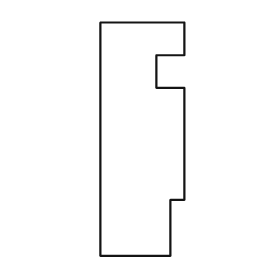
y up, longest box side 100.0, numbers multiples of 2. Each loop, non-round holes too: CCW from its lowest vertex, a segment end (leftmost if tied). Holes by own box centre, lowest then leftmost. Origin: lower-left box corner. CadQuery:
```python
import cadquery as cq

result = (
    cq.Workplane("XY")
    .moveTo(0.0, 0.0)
    .lineTo(30.0, 0.0)
    .lineTo(30.0, 24.0)
    .lineTo(36.0, 24.0)
    .lineTo(36.0, 72.0)
    .lineTo(24.0, 72.0)
    .lineTo(24.0, 86.0)
    .lineTo(36.0, 86.0)
    .lineTo(36.0, 100.0)
    .lineTo(0.0, 100.0)
    .close()
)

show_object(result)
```